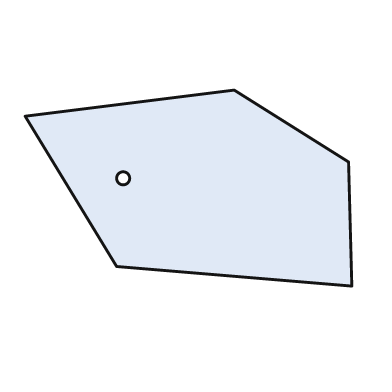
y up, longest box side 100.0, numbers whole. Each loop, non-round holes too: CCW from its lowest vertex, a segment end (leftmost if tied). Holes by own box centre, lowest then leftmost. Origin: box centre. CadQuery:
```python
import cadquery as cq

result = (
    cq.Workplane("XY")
    .moveTo(50.0, -30.0)
    .lineTo(49.0, 8.0)
    .lineTo(14.0, 30.0)
    .lineTo(-50.0, 22.0)
    .lineTo(-22.0, -24.0)
    .close()
    .moveTo(-20.0, 3.0)
    .circle(2.0)
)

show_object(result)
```